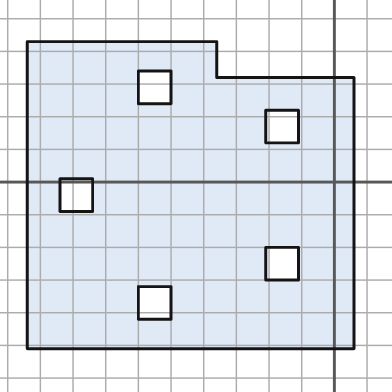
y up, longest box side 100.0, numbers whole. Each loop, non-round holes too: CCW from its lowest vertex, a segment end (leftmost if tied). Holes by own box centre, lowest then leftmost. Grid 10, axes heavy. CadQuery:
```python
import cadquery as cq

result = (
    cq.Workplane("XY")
    .moveTo(-94.0, -51.0)
    .lineTo(6.0, -51.0)
    .lineTo(6.0, 32.0)
    .lineTo(-36.0, 32.0)
    .lineTo(-36.0, 43.0)
    .lineTo(-94.0, 43.0)
    .close()
    .moveTo(-60.0, -42.0)
    .lineTo(-50.0, -42.0)
    .lineTo(-50.0, -32.0)
    .lineTo(-60.0, -32.0)
    .close()
    .moveTo(-21.0, -30.0)
    .lineTo(-11.0, -30.0)
    .lineTo(-11.0, -20.0)
    .lineTo(-21.0, -20.0)
    .close()
    .moveTo(-84.0, -9.0)
    .lineTo(-74.0, -9.0)
    .lineTo(-74.0, 1.0)
    .lineTo(-84.0, 1.0)
    .close()
    .moveTo(-21.0, 12.0)
    .lineTo(-11.0, 12.0)
    .lineTo(-11.0, 22.0)
    .lineTo(-21.0, 22.0)
    .close()
    .moveTo(-60.0, 24.0)
    .lineTo(-50.0, 24.0)
    .lineTo(-50.0, 34.0)
    .lineTo(-60.0, 34.0)
    .close()
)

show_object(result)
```